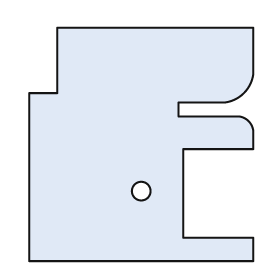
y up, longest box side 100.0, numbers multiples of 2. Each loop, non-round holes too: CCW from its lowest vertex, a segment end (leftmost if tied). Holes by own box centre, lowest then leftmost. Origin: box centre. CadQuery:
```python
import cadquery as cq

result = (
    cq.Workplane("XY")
    .moveTo(-48.0, -50.0)
    .lineTo(48.0, -50.0)
    .lineTo(48.0, -40.0)
    .lineTo(18.0, -40.0)
    .lineTo(18.0, -2.0)
    .lineTo(48.0, -2.0)
    .lineTo(48.0, 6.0)
    .threePointArc((46.0, 10.0), (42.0, 12.0))
    .lineTo(16.0, 12.0)
    .lineTo(16.0, 18.0)
    .lineTo(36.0, 18.0)
    .threePointArc((44.0, 22.0), (48.0, 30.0))
    .lineTo(48.0, 50.0)
    .lineTo(-36.0, 50.0)
    .lineTo(-36.0, 22.0)
    .lineTo(-48.0, 22.0)
    .close()
    .moveTo(0.0, -20.0)
    .circle(4.0)
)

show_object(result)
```